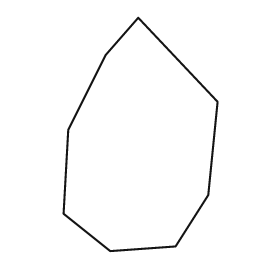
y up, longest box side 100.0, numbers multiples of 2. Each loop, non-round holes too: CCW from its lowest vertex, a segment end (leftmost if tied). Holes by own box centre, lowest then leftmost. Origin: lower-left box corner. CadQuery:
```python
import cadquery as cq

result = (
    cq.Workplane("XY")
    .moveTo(20.0, 0.0)
    .lineTo(48.0, 2.0)
    .lineTo(62.0, 24.0)
    .lineTo(66.0, 64.0)
    .lineTo(32.0, 100.0)
    .lineTo(18.0, 84.0)
    .lineTo(2.0, 52.0)
    .lineTo(0.0, 16.0)
    .close()
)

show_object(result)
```